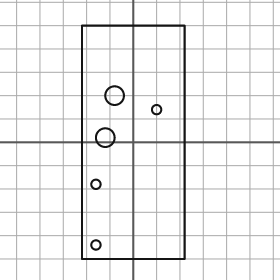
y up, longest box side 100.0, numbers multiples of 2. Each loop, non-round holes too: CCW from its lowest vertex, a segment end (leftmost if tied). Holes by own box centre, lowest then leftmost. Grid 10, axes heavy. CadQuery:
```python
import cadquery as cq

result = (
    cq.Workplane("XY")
    .moveTo(-22.0, -50.0)
    .lineTo(22.0, -50.0)
    .lineTo(22.0, 50.0)
    .lineTo(-22.0, 50.0)
    .close()
    .moveTo(-16.0, -44.0)
    .circle(2.0)
    .moveTo(-16.0, -18.0)
    .circle(2.0)
    .moveTo(-12.0, 2.0)
    .circle(4.0)
    .moveTo(10.0, 14.0)
    .circle(2.0)
    .moveTo(-8.0, 20.0)
    .circle(4.0)
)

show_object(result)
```